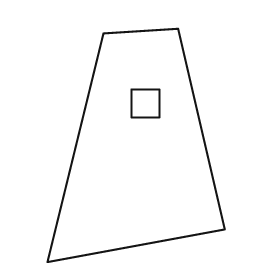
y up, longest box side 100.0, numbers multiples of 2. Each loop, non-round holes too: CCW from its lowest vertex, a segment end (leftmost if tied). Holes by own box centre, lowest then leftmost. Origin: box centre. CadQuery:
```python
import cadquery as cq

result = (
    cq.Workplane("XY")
    .moveTo(-38.0, -50.0)
    .lineTo(38.0, -36.0)
    .lineTo(18.0, 50.0)
    .lineTo(-14.0, 48.0)
    .close()
    .moveTo(-2.0, 12.0)
    .lineTo(10.0, 12.0)
    .lineTo(10.0, 24.0)
    .lineTo(-2.0, 24.0)
    .close()
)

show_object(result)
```